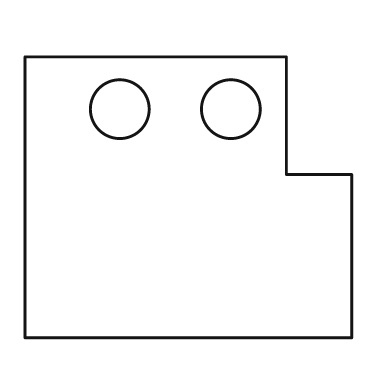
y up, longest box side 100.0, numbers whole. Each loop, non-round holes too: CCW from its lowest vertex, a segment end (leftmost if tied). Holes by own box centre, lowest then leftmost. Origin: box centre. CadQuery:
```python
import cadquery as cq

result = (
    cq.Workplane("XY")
    .moveTo(-50.0, -43.0)
    .lineTo(50.0, -43.0)
    .lineTo(50.0, 7.0)
    .lineTo(30.0, 7.0)
    .lineTo(30.0, 43.0)
    .lineTo(-50.0, 43.0)
    .close()
    .moveTo(-21.0, 27.0)
    .circle(9.0)
    .moveTo(13.0, 27.0)
    .circle(9.0)
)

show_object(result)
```